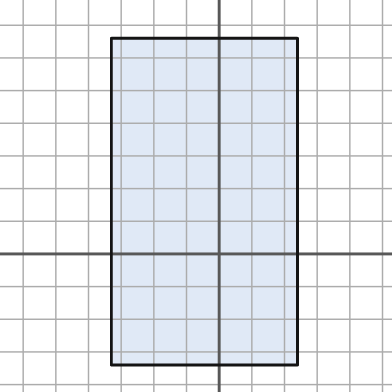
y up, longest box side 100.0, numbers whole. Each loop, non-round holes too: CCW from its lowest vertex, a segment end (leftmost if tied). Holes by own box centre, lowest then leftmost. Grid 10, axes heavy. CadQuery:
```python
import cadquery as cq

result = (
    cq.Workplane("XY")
    .moveTo(-33.0, -34.0)
    .lineTo(24.0, -34.0)
    .lineTo(24.0, 66.0)
    .lineTo(-33.0, 66.0)
    .close()
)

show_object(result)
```